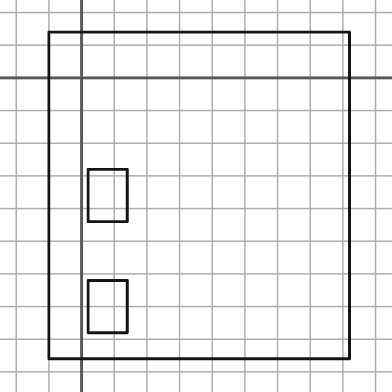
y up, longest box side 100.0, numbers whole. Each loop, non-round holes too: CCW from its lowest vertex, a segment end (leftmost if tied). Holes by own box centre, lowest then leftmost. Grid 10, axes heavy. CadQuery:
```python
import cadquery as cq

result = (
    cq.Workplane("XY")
    .moveTo(-10.0, -86.0)
    .lineTo(82.0, -86.0)
    .lineTo(82.0, 14.0)
    .lineTo(-10.0, 14.0)
    .close()
    .moveTo(2.0, -78.0)
    .lineTo(14.0, -78.0)
    .lineTo(14.0, -62.0)
    .lineTo(2.0, -62.0)
    .close()
    .moveTo(2.0, -44.0)
    .lineTo(14.0, -44.0)
    .lineTo(14.0, -28.0)
    .lineTo(2.0, -28.0)
    .close()
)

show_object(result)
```